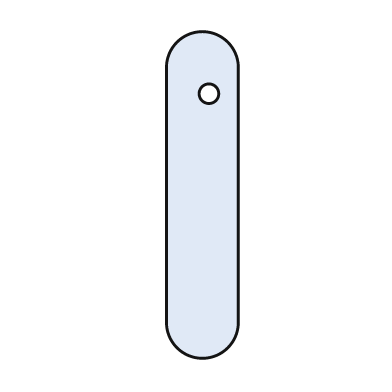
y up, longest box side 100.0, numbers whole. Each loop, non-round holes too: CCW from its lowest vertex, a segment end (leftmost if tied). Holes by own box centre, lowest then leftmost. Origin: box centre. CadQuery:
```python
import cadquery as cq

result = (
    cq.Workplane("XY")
    .moveTo(-11.0, -39.0)
    .threePointArc((0.0, -50.0), (11.0, -39.0))
    .lineTo(11.0, 39.0)
    .threePointArc((0.0, 50.0), (-11.0, 39.0))
    .close()
    .moveTo(2.0, 31.0)
    .circle(3.0)
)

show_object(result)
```